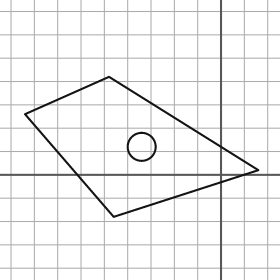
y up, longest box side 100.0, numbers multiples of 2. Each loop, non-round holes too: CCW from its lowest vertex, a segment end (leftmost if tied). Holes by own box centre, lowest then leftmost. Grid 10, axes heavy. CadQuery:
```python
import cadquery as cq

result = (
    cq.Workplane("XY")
    .moveTo(-46.0, -18.0)
    .lineTo(16.0, 2.0)
    .lineTo(-48.0, 42.0)
    .lineTo(-84.0, 26.0)
    .close()
    .moveTo(-34.0, 12.0)
    .circle(6.0)
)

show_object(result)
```